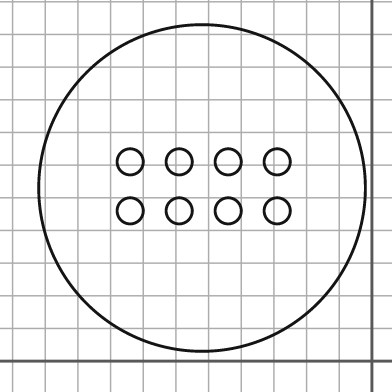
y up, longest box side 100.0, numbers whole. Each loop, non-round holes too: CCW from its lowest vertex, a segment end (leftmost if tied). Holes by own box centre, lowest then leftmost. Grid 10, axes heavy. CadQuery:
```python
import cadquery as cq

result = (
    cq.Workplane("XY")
    .moveTo(-52.0, 53.0)
    .circle(50.0)
    .moveTo(-74.0, 46.0)
    .circle(4.0)
    .moveTo(-59.0, 46.0)
    .circle(4.0)
    .moveTo(-44.0, 46.0)
    .circle(4.0)
    .moveTo(-29.0, 46.0)
    .circle(4.0)
    .moveTo(-74.0, 61.0)
    .circle(4.0)
    .moveTo(-59.0, 61.0)
    .circle(4.0)
    .moveTo(-44.0, 61.0)
    .circle(4.0)
    .moveTo(-29.0, 61.0)
    .circle(4.0)
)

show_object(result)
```